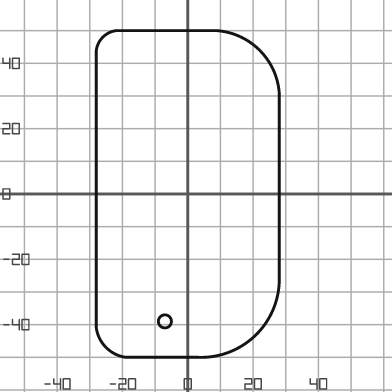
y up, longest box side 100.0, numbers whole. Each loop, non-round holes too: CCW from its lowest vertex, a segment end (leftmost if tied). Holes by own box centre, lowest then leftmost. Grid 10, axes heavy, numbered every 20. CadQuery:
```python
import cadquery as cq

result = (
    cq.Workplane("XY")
    .moveTo(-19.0, -50.0)
    .lineTo(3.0, -50.0)
    .threePointArc((21.0, -43.0), (28.0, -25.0))
    .lineTo(28.0, 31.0)
    .threePointArc((22.0, 44.0), (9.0, 50.0))
    .lineTo(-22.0, 50.0)
    .threePointArc((-26.0, 48.0), (-28.0, 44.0))
    .lineTo(-28.0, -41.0)
    .threePointArc((-25.0, -47.0), (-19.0, -50.0))
    .close()
    .moveTo(-7.0, -39.0)
    .circle(2.0)
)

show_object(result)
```